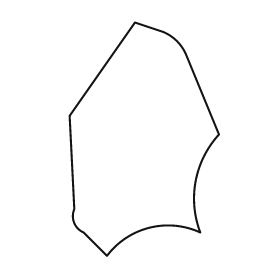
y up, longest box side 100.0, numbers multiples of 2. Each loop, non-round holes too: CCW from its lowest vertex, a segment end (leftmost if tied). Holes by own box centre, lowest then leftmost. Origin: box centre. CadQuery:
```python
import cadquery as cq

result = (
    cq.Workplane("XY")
    .moveTo(-16.0, -50.0)
    .threePointArc((2.0, -38.0), (24.0, -40.0))
    .threePointArc((22.0, -18.0), (32.0, 2.0))
    .lineTo(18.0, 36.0)
    .threePointArc((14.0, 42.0), (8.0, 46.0))
    .lineTo(-4.0, 50.0)
    .lineTo(-32.0, 10.0)
    .lineTo(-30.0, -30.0)
    .threePointArc((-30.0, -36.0), (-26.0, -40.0))
    .close()
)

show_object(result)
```